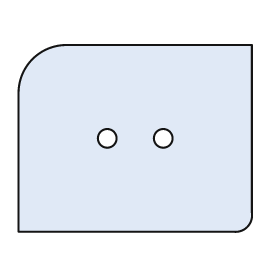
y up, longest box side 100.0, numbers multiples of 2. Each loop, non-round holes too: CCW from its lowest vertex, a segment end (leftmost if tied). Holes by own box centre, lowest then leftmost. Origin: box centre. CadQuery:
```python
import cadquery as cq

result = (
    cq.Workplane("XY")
    .moveTo(-50.0, -40.0)
    .lineTo(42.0, -40.0)
    .threePointArc((48.0, -38.0), (50.0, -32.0))
    .lineTo(50.0, 40.0)
    .lineTo(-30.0, 40.0)
    .threePointArc((-44.0, 34.0), (-50.0, 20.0))
    .close()
    .moveTo(-12.0, 0.0)
    .circle(4.0)
    .moveTo(12.0, 0.0)
    .circle(4.0)
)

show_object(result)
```